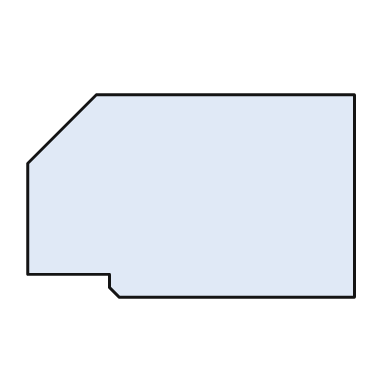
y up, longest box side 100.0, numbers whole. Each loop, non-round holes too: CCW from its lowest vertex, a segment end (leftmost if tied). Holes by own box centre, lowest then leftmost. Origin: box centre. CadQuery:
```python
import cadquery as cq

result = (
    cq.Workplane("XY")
    .moveTo(-22.0, -31.0)
    .lineTo(50.0, -31.0)
    .lineTo(50.0, 31.0)
    .lineTo(-29.0, 31.0)
    .lineTo(-50.0, 10.0)
    .lineTo(-50.0, -24.0)
    .lineTo(-25.0, -24.0)
    .lineTo(-25.0, -28.0)
    .close()
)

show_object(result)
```